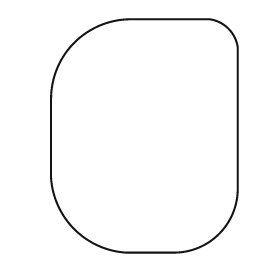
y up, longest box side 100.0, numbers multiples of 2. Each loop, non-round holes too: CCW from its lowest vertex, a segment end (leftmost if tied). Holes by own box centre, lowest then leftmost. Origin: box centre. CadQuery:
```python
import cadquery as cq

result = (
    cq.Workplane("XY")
    .moveTo(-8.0, -50.0)
    .lineTo(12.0, -50.0)
    .threePointArc((32.0, -42.0), (40.0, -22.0))
    .lineTo(40.0, 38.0)
    .threePointArc((36.0, 46.0), (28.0, 50.0))
    .lineTo(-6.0, 50.0)
    .threePointArc((-30.0, 40.0), (-40.0, 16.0))
    .lineTo(-40.0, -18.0)
    .threePointArc((-30.0, -40.0), (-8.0, -50.0))
    .close()
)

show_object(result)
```